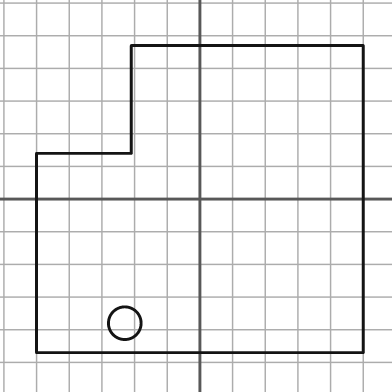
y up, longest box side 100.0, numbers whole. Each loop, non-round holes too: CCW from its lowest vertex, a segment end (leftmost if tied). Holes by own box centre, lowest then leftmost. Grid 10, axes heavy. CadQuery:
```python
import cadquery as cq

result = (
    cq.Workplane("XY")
    .moveTo(-50.0, -47.0)
    .lineTo(50.0, -47.0)
    .lineTo(50.0, 47.0)
    .lineTo(-21.0, 47.0)
    .lineTo(-21.0, 14.0)
    .lineTo(-50.0, 14.0)
    .close()
    .moveTo(-23.0, -38.0)
    .circle(5.0)
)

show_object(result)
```